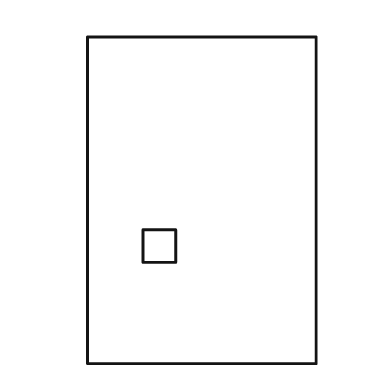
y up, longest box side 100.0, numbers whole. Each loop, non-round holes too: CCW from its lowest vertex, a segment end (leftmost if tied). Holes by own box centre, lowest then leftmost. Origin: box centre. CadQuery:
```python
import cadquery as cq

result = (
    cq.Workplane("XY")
    .moveTo(-35.0, -50.0)
    .lineTo(35.0, -50.0)
    .lineTo(35.0, 50.0)
    .lineTo(-35.0, 50.0)
    .close()
    .moveTo(-18.0, -19.0)
    .lineTo(-8.0, -19.0)
    .lineTo(-8.0, -9.0)
    .lineTo(-18.0, -9.0)
    .close()
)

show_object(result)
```